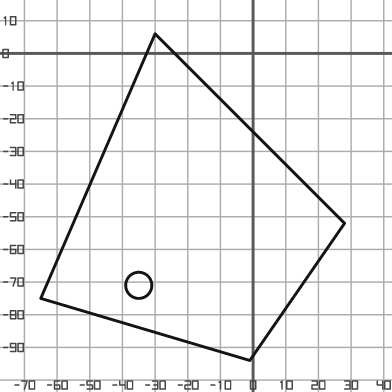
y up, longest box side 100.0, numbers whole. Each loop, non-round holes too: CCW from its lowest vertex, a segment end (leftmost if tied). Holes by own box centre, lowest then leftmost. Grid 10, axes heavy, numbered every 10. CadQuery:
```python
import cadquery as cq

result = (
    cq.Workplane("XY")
    .moveTo(-1.0, -94.0)
    .lineTo(28.0, -52.0)
    .lineTo(-30.0, 6.0)
    .lineTo(-65.0, -75.0)
    .close()
    .moveTo(-35.0, -71.0)
    .circle(4.0)
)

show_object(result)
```